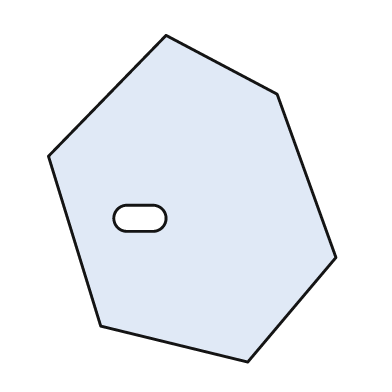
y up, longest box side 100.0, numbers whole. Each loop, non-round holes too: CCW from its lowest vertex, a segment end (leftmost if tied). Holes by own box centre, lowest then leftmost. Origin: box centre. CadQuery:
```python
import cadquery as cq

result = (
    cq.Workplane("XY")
    .moveTo(17.0, -50.0)
    .lineTo(44.0, -18.0)
    .lineTo(26.0, 32.0)
    .lineTo(-8.0, 50.0)
    .lineTo(-44.0, 13.0)
    .lineTo(-28.0, -39.0)
    .close()
    .moveTo(-20.0, -10.0)
    .lineTo(-12.0, -10.0)
    .threePointArc((-8.0, -6.0), (-12.0, -2.0))
    .lineTo(-20.0, -2.0)
    .threePointArc((-24.0, -6.0), (-20.0, -10.0))
    .close()
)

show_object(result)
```